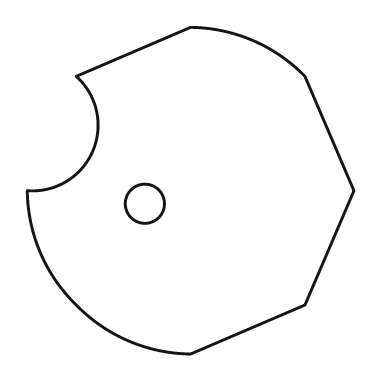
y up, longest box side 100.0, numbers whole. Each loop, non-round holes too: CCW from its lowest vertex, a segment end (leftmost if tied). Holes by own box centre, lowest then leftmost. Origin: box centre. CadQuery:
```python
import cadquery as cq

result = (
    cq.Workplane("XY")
    .moveTo(0.0, -50.0)
    .lineTo(35.0, -35.0)
    .lineTo(50.0, 0.0)
    .lineTo(35.0, 35.0)
    .threePointArc((19.0, 46.0), (0.0, 50.0))
    .lineTo(-35.0, 35.0)
    .threePointArc((-30.0, 12.0), (-50.0, 0.0))
    .threePointArc((-46.0, -19.0), (-35.0, -35.0))
    .threePointArc((-19.0, -46.0), (0.0, -50.0))
    .close()
    .moveTo(-14.0, -4.0)
    .circle(6.0)
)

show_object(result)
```